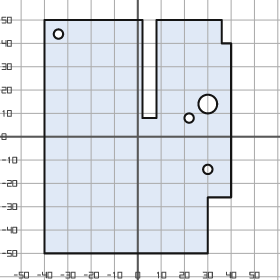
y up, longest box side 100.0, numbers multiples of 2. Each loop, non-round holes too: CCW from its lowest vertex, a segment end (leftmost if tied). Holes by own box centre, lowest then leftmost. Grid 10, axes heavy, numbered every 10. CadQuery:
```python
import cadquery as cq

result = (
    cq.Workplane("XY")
    .moveTo(-40.0, -50.0)
    .lineTo(30.0, -50.0)
    .lineTo(30.0, -26.0)
    .lineTo(40.0, -26.0)
    .lineTo(40.0, 40.0)
    .lineTo(36.0, 40.0)
    .lineTo(36.0, 50.0)
    .lineTo(8.0, 50.0)
    .lineTo(8.0, 8.0)
    .lineTo(2.0, 8.0)
    .lineTo(2.0, 50.0)
    .lineTo(-40.0, 50.0)
    .close()
    .moveTo(30.0, -14.0)
    .circle(2.0)
    .moveTo(22.0, 8.0)
    .circle(2.0)
    .moveTo(30.0, 14.0)
    .circle(4.0)
    .moveTo(-34.0, 44.0)
    .circle(2.0)
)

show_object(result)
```